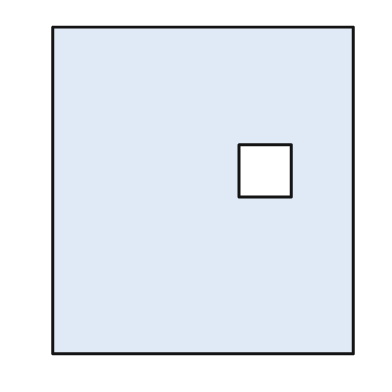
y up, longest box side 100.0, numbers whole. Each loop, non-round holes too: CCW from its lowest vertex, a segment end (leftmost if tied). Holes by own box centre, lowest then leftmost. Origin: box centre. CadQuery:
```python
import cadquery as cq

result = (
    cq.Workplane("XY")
    .moveTo(-46.0, -50.0)
    .lineTo(46.0, -50.0)
    .lineTo(46.0, 50.0)
    .lineTo(-46.0, 50.0)
    .close()
    .moveTo(11.0, -2.0)
    .lineTo(27.0, -2.0)
    .lineTo(27.0, 14.0)
    .lineTo(11.0, 14.0)
    .close()
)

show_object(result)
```